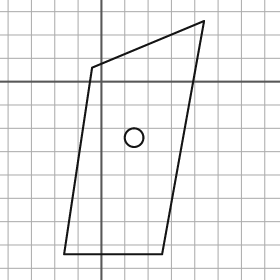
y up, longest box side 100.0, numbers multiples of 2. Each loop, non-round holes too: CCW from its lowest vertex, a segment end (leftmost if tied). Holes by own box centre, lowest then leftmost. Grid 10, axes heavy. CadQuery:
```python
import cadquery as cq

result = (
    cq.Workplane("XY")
    .moveTo(-16.0, -74.0)
    .lineTo(26.0, -74.0)
    .lineTo(44.0, 26.0)
    .lineTo(-4.0, 6.0)
    .close()
    .moveTo(14.0, -24.0)
    .circle(4.0)
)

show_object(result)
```